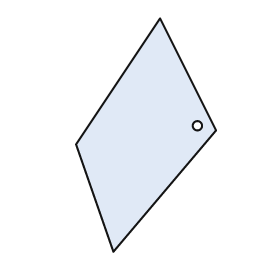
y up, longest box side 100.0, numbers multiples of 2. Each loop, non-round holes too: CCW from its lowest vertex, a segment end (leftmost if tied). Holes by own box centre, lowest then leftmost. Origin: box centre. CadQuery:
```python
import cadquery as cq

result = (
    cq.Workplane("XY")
    .moveTo(-14.0, -50.0)
    .lineTo(30.0, 2.0)
    .lineTo(6.0, 50.0)
    .lineTo(-30.0, -4.0)
    .close()
    .moveTo(22.0, 4.0)
    .circle(2.0)
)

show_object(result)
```